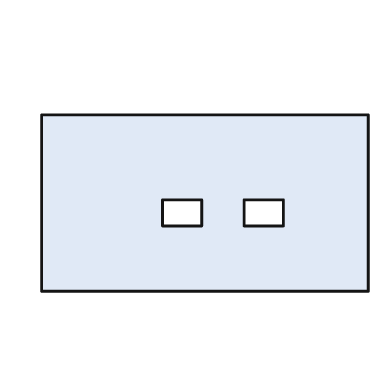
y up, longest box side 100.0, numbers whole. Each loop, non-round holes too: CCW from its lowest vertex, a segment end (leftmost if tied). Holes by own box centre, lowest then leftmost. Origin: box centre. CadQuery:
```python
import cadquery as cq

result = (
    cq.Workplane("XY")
    .moveTo(-50.0, -27.0)
    .lineTo(50.0, -27.0)
    .lineTo(50.0, 27.0)
    .lineTo(-50.0, 27.0)
    .close()
    .moveTo(-13.0, -7.0)
    .lineTo(-1.0, -7.0)
    .lineTo(-1.0, 1.0)
    .lineTo(-13.0, 1.0)
    .close()
    .moveTo(12.0, -7.0)
    .lineTo(24.0, -7.0)
    .lineTo(24.0, 1.0)
    .lineTo(12.0, 1.0)
    .close()
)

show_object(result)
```